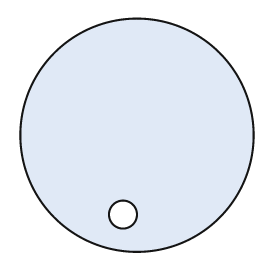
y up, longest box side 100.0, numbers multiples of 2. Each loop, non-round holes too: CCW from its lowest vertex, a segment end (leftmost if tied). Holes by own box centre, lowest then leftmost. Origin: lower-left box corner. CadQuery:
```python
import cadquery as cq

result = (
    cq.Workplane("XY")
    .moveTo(50.0, 50.0)
    .circle(50.0)
    .moveTo(44.0, 16.0)
    .circle(6.0)
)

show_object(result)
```